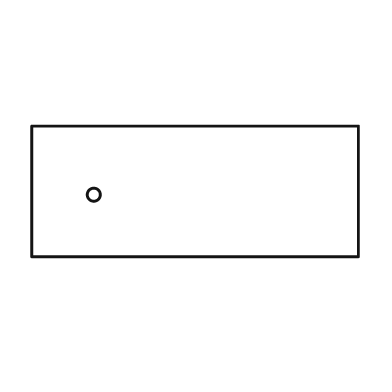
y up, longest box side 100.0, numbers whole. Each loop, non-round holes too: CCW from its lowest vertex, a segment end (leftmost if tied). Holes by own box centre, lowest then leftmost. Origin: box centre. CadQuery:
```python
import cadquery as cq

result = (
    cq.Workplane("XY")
    .moveTo(-50.0, -20.0)
    .lineTo(50.0, -20.0)
    .lineTo(50.0, 20.0)
    .lineTo(-50.0, 20.0)
    .close()
    .moveTo(-31.0, -1.0)
    .circle(2.0)
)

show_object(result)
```